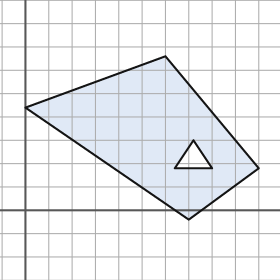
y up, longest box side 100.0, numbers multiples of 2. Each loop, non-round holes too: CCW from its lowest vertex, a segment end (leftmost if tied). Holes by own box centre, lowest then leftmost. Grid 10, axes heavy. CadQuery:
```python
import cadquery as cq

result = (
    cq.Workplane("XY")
    .moveTo(70.0, -4.0)
    .lineTo(100.0, 18.0)
    .lineTo(60.0, 66.0)
    .lineTo(0.0, 44.0)
    .close()
    .moveTo(64.0, 18.0)
    .lineTo(80.0, 18.0)
    .lineTo(72.0, 30.0)
    .close()
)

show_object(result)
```